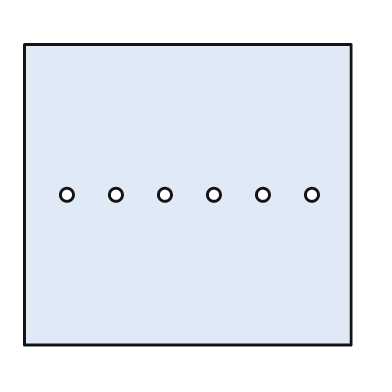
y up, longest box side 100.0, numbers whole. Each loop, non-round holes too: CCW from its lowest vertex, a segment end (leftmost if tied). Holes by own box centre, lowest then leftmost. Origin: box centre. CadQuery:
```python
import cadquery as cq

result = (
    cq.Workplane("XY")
    .moveTo(-50.0, -46.0)
    .lineTo(50.0, -46.0)
    .lineTo(50.0, 46.0)
    .lineTo(-50.0, 46.0)
    .close()
    .moveTo(-37.0, 0.0)
    .circle(2.0)
    .moveTo(-22.0, 0.0)
    .circle(2.0)
    .moveTo(-7.0, 0.0)
    .circle(2.0)
    .moveTo(8.0, 0.0)
    .circle(2.0)
    .moveTo(23.0, 0.0)
    .circle(2.0)
    .moveTo(38.0, 0.0)
    .circle(2.0)
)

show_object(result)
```